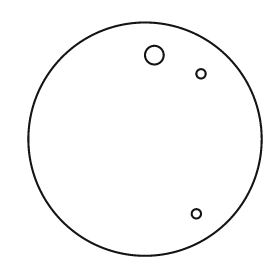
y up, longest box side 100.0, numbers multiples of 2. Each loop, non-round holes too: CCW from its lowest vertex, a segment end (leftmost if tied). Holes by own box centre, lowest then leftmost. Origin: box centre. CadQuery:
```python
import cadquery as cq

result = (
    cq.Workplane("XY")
    .moveTo(0.0, 0.0)
    .circle(50.0)
    .moveTo(22.0, -32.0)
    .circle(2.0)
    .moveTo(24.0, 28.0)
    .circle(2.0)
    .moveTo(4.0, 36.0)
    .circle(4.0)
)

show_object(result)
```